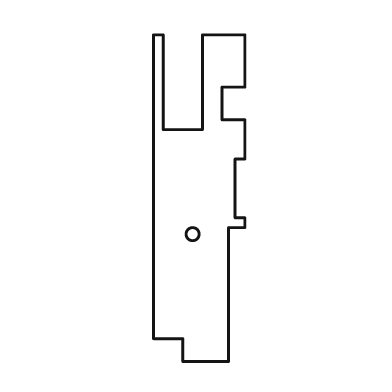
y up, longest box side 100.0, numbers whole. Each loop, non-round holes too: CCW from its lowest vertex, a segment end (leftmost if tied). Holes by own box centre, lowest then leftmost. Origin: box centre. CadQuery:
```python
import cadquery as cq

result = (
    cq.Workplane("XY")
    .moveTo(-5.0, -50.0)
    .lineTo(9.0, -50.0)
    .lineTo(9.0, -9.0)
    .lineTo(14.0, -9.0)
    .lineTo(14.0, -6.0)
    .lineTo(11.0, -6.0)
    .lineTo(11.0, 12.0)
    .lineTo(14.0, 12.0)
    .lineTo(14.0, 24.0)
    .lineTo(7.0, 24.0)
    .lineTo(7.0, 34.0)
    .lineTo(14.0, 34.0)
    .lineTo(14.0, 50.0)
    .lineTo(1.0, 50.0)
    .lineTo(1.0, 21.0)
    .lineTo(-11.0, 21.0)
    .lineTo(-11.0, 50.0)
    .lineTo(-14.0, 50.0)
    .lineTo(-14.0, -43.0)
    .lineTo(-5.0, -43.0)
    .close()
    .moveTo(-2.0, -11.0)
    .circle(2.0)
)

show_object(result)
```